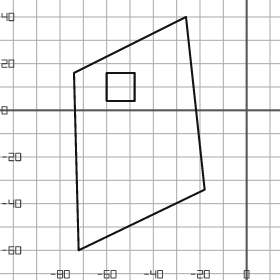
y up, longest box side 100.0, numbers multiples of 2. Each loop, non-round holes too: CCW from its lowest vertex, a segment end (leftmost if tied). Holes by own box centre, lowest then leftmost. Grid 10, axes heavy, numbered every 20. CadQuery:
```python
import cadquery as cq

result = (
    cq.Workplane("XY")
    .moveTo(-72.0, -60.0)
    .lineTo(-18.0, -34.0)
    .lineTo(-26.0, 40.0)
    .lineTo(-74.0, 16.0)
    .close()
    .moveTo(-60.0, 4.0)
    .lineTo(-48.0, 4.0)
    .lineTo(-48.0, 16.0)
    .lineTo(-60.0, 16.0)
    .close()
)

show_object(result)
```